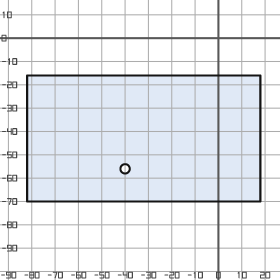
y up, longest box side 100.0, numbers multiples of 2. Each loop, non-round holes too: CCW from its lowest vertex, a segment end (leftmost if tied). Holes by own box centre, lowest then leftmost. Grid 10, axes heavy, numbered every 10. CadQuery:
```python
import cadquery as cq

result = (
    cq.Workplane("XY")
    .moveTo(-82.0, -70.0)
    .lineTo(18.0, -70.0)
    .lineTo(18.0, -16.0)
    .lineTo(-82.0, -16.0)
    .close()
    .moveTo(-40.0, -56.0)
    .circle(2.0)
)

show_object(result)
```